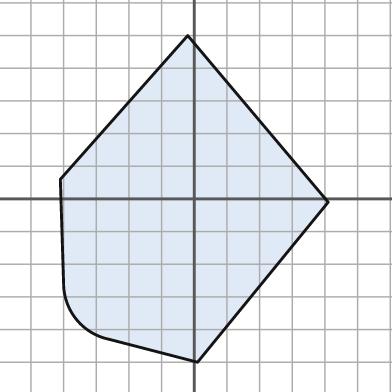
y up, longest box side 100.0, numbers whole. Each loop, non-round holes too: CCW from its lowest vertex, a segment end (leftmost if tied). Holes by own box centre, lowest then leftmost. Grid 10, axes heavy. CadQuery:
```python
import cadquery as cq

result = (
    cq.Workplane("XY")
    .moveTo(1.0, -50.0)
    .lineTo(41.0, -1.0)
    .lineTo(-2.0, 50.0)
    .lineTo(-41.0, 6.0)
    .lineTo(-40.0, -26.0)
    .threePointArc((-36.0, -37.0), (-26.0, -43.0))
    .close()
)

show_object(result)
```